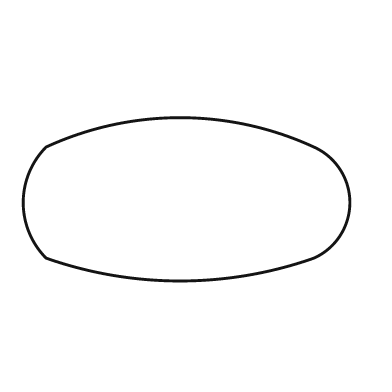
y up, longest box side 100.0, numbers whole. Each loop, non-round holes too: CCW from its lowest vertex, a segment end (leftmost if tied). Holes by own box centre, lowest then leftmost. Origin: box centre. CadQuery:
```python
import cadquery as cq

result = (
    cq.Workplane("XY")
    .moveTo(-43.0, -18.0)
    .threePointArc((-2.0, -25.0), (39.0, -18.0))
    .threePointArc((50.0, -1.0), (39.0, 16.0))
    .threePointArc((-2.0, 25.0), (-43.0, 16.0))
    .threePointArc((-50.0, -1.0), (-43.0, -18.0))
    .close()
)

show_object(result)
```